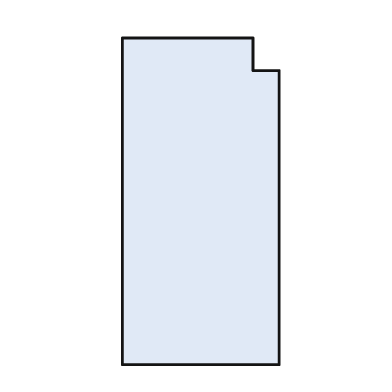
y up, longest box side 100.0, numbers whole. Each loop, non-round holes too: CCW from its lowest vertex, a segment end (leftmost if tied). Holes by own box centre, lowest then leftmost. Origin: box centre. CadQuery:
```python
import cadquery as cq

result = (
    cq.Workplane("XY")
    .moveTo(-24.0, -50.0)
    .lineTo(24.0, -50.0)
    .lineTo(24.0, 40.0)
    .lineTo(16.0, 40.0)
    .lineTo(16.0, 50.0)
    .lineTo(-24.0, 50.0)
    .close()
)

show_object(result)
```